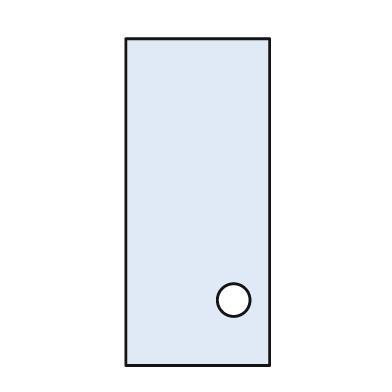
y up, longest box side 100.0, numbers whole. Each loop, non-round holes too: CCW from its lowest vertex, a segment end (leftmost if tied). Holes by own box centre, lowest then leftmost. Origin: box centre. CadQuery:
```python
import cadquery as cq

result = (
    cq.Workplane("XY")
    .moveTo(-22.0, -50.0)
    .lineTo(22.0, -50.0)
    .lineTo(22.0, 50.0)
    .lineTo(-22.0, 50.0)
    .close()
    .moveTo(11.0, -30.0)
    .circle(5.0)
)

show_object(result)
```